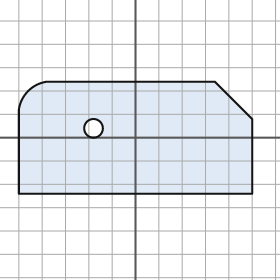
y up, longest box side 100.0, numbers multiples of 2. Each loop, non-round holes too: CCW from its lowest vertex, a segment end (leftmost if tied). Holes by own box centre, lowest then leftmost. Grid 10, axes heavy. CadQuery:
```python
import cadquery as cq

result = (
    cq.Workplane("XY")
    .moveTo(-50.0, -24.0)
    .lineTo(50.0, -24.0)
    .lineTo(50.0, 8.0)
    .lineTo(34.0, 24.0)
    .lineTo(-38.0, 24.0)
    .threePointArc((-46.0, 20.0), (-50.0, 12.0))
    .close()
    .moveTo(-18.0, 4.0)
    .circle(4.0)
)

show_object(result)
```